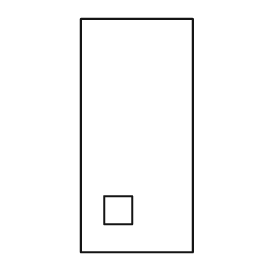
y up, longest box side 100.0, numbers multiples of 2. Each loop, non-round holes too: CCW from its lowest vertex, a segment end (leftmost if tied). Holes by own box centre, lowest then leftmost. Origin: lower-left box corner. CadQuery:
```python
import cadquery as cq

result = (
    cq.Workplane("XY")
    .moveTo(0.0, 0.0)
    .lineTo(48.0, 0.0)
    .lineTo(48.0, 100.0)
    .lineTo(0.0, 100.0)
    .close()
    .moveTo(10.0, 12.0)
    .lineTo(22.0, 12.0)
    .lineTo(22.0, 24.0)
    .lineTo(10.0, 24.0)
    .close()
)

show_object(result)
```